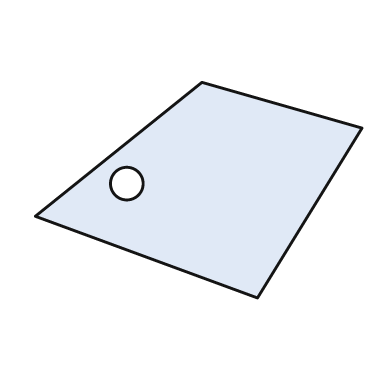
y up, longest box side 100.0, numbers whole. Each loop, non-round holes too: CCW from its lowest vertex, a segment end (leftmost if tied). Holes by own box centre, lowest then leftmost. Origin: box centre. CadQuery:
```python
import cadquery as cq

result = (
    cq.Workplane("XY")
    .moveTo(18.0, -33.0)
    .lineTo(50.0, 19.0)
    .lineTo(1.0, 33.0)
    .lineTo(-50.0, -8.0)
    .close()
    .moveTo(-22.0, 2.0)
    .circle(5.0)
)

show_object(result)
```